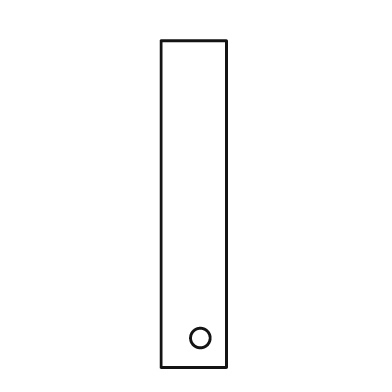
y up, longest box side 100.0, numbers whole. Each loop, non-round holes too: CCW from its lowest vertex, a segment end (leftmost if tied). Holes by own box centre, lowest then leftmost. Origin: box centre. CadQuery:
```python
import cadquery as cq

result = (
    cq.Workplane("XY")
    .moveTo(-10.0, -50.0)
    .lineTo(10.0, -50.0)
    .lineTo(10.0, 50.0)
    .lineTo(-10.0, 50.0)
    .close()
    .moveTo(2.0, -41.0)
    .circle(3.0)
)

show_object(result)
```